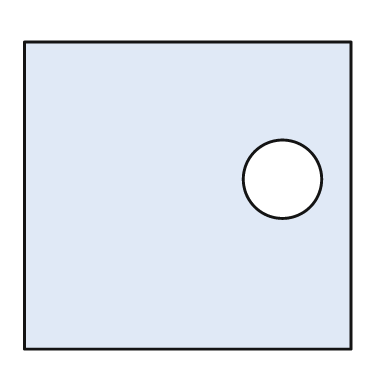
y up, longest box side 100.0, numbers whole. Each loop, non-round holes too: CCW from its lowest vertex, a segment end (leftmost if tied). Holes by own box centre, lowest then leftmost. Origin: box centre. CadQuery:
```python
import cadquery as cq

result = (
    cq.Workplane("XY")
    .moveTo(-50.0, -47.0)
    .lineTo(50.0, -47.0)
    .lineTo(50.0, 47.0)
    .lineTo(-50.0, 47.0)
    .close()
    .moveTo(29.0, 5.0)
    .circle(12.0)
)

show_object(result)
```